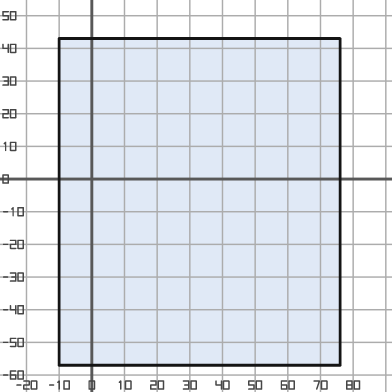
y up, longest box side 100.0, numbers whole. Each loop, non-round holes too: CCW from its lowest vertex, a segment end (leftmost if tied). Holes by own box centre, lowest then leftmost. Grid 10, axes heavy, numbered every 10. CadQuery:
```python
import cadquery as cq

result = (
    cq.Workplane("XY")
    .moveTo(-10.0, -57.0)
    .lineTo(76.0, -57.0)
    .lineTo(76.0, 43.0)
    .lineTo(-10.0, 43.0)
    .close()
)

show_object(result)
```